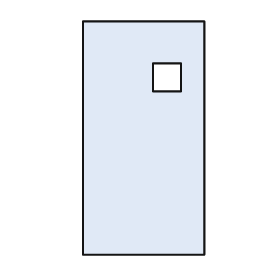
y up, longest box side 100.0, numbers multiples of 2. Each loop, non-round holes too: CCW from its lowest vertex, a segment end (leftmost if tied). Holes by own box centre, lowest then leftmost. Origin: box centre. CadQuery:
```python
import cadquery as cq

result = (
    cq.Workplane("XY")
    .moveTo(-26.0, -50.0)
    .lineTo(26.0, -50.0)
    .lineTo(26.0, 50.0)
    .lineTo(-26.0, 50.0)
    .close()
    .moveTo(4.0, 20.0)
    .lineTo(16.0, 20.0)
    .lineTo(16.0, 32.0)
    .lineTo(4.0, 32.0)
    .close()
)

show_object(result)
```